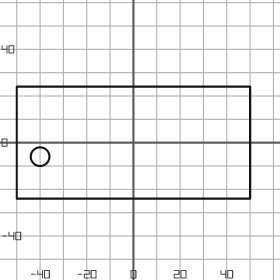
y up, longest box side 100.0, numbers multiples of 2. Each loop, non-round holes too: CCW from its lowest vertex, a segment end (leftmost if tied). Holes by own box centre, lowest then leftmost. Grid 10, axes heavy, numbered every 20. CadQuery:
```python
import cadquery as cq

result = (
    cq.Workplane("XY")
    .moveTo(-50.0, -24.0)
    .lineTo(50.0, -24.0)
    .lineTo(50.0, 24.0)
    .lineTo(-50.0, 24.0)
    .close()
    .moveTo(-40.0, -6.0)
    .circle(4.0)
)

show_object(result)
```